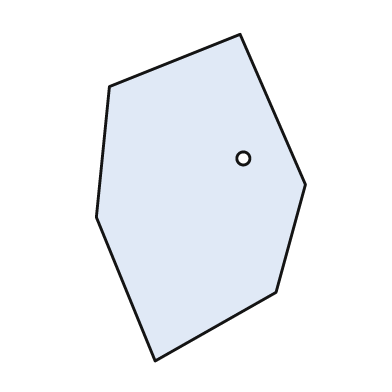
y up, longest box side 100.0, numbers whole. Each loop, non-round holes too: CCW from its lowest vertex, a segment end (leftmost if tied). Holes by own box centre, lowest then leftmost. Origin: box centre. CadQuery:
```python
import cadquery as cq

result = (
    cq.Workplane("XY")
    .moveTo(-14.0, -50.0)
    .lineTo(23.0, -29.0)
    .lineTo(32.0, 4.0)
    .lineTo(12.0, 50.0)
    .lineTo(-28.0, 34.0)
    .lineTo(-32.0, -6.0)
    .close()
    .moveTo(13.0, 12.0)
    .circle(2.0)
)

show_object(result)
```